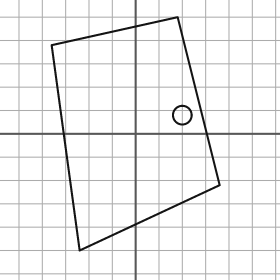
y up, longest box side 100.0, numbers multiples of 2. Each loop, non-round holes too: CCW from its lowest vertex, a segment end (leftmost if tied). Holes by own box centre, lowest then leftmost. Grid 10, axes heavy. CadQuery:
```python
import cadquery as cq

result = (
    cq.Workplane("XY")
    .moveTo(-24.0, -50.0)
    .lineTo(36.0, -22.0)
    .lineTo(18.0, 50.0)
    .lineTo(-36.0, 38.0)
    .close()
    .moveTo(20.0, 8.0)
    .circle(4.0)
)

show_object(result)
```